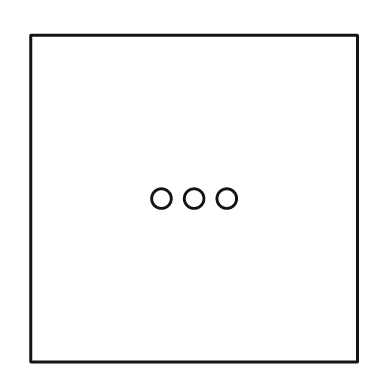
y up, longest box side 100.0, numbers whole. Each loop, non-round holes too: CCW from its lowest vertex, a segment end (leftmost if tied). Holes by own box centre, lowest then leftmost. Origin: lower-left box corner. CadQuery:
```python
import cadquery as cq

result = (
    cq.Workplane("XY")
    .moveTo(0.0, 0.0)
    .lineTo(100.0, 0.0)
    .lineTo(100.0, 100.0)
    .lineTo(0.0, 100.0)
    .close()
    .moveTo(40.0, 50.0)
    .circle(3.0)
    .moveTo(50.0, 50.0)
    .circle(3.0)
    .moveTo(60.0, 50.0)
    .circle(3.0)
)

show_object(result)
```